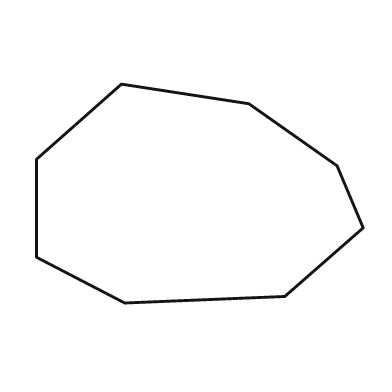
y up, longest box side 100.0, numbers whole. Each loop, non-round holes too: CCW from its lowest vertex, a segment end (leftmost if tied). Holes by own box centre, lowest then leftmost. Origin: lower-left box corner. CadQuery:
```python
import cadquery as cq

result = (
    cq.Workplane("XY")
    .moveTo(27.0, 0.0)
    .lineTo(76.0, 2.0)
    .lineTo(100.0, 23.0)
    .lineTo(92.0, 42.0)
    .lineTo(65.0, 61.0)
    .lineTo(26.0, 67.0)
    .lineTo(0.0, 44.0)
    .lineTo(0.0, 14.0)
    .close()
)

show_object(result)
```